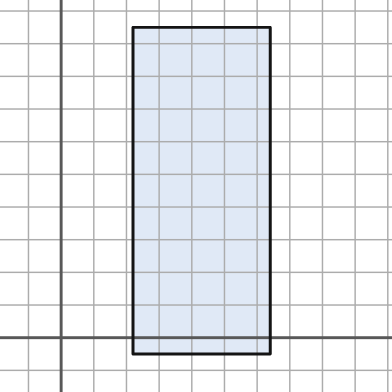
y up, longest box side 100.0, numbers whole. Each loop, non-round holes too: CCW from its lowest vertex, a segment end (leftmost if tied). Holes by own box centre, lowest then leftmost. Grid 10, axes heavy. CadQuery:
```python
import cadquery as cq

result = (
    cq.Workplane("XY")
    .moveTo(22.0, -5.0)
    .lineTo(64.0, -5.0)
    .lineTo(64.0, 95.0)
    .lineTo(22.0, 95.0)
    .close()
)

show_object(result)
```